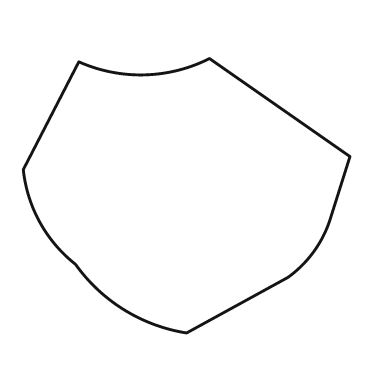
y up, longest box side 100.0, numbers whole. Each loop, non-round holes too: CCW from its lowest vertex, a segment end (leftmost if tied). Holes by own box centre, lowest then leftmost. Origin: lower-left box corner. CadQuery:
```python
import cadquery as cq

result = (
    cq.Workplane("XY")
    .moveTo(50.0, 0.0)
    .lineTo(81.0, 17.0)
    .threePointArc((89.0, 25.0), (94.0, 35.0))
    .lineTo(100.0, 54.0)
    .lineTo(57.0, 84.0)
    .threePointArc((37.0, 79.0), (17.0, 83.0))
    .lineTo(0.0, 50.0)
    .threePointArc((5.0, 34.0), (16.0, 21.0))
    .threePointArc((31.0, 7.0), (50.0, 0.0))
    .close()
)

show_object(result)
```